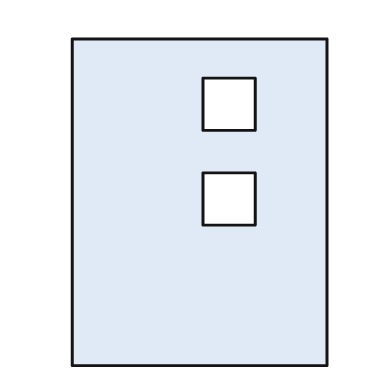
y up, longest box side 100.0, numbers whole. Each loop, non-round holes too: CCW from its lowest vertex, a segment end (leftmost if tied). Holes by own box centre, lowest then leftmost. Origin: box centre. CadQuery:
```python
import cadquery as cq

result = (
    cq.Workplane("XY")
    .moveTo(-39.0, -50.0)
    .lineTo(39.0, -50.0)
    .lineTo(39.0, 50.0)
    .lineTo(-39.0, 50.0)
    .close()
    .moveTo(1.0, -7.0)
    .lineTo(17.0, -7.0)
    .lineTo(17.0, 9.0)
    .lineTo(1.0, 9.0)
    .close()
    .moveTo(1.0, 22.0)
    .lineTo(17.0, 22.0)
    .lineTo(17.0, 38.0)
    .lineTo(1.0, 38.0)
    .close()
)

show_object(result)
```